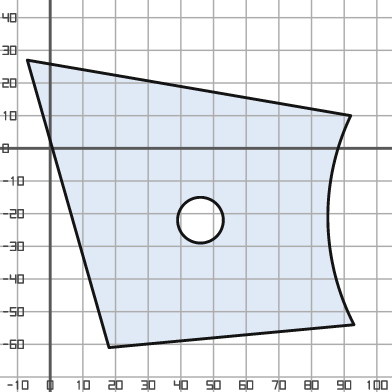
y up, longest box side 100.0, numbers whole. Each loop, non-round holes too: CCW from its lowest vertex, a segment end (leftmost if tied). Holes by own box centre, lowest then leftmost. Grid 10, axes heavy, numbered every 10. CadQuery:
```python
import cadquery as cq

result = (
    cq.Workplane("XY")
    .moveTo(18.0, -61.0)
    .lineTo(93.0, -54.0)
    .threePointArc((85.0, -22.0), (92.0, 10.0))
    .lineTo(-7.0, 27.0)
    .close()
    .moveTo(46.0, -22.0)
    .circle(7.0)
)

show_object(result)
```